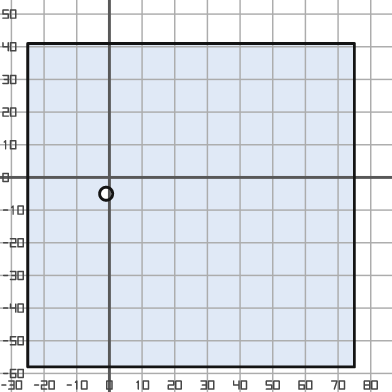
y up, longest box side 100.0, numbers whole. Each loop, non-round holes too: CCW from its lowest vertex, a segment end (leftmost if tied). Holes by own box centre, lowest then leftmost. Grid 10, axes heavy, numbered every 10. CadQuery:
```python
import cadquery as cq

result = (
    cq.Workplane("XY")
    .moveTo(-25.0, -58.0)
    .lineTo(75.0, -58.0)
    .lineTo(75.0, 41.0)
    .lineTo(-25.0, 41.0)
    .close()
    .moveTo(-1.0, -5.0)
    .circle(2.0)
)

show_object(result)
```